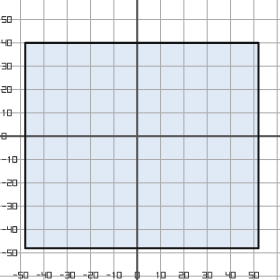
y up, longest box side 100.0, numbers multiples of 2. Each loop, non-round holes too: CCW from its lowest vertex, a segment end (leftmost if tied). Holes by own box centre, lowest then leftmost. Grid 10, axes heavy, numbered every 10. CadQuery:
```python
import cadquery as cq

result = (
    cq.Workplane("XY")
    .moveTo(-48.0, -48.0)
    .lineTo(52.0, -48.0)
    .lineTo(52.0, 40.0)
    .lineTo(-48.0, 40.0)
    .close()
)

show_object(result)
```